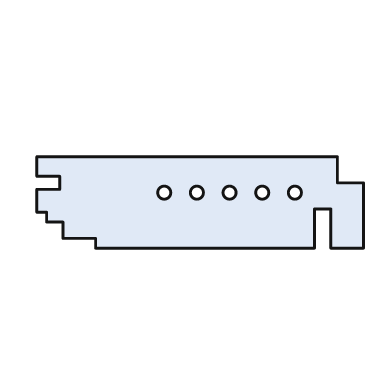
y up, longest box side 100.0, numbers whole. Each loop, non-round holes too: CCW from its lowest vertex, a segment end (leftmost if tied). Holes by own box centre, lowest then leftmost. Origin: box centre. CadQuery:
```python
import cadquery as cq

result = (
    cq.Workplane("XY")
    .moveTo(-32.0, -14.0)
    .lineTo(35.0, -14.0)
    .lineTo(35.0, -2.0)
    .lineTo(40.0, -2.0)
    .lineTo(40.0, -14.0)
    .lineTo(50.0, -14.0)
    .lineTo(50.0, 6.0)
    .lineTo(42.0, 6.0)
    .lineTo(42.0, 14.0)
    .lineTo(-50.0, 14.0)
    .lineTo(-50.0, 8.0)
    .lineTo(-43.0, 8.0)
    .lineTo(-43.0, 4.0)
    .lineTo(-50.0, 4.0)
    .lineTo(-50.0, -3.0)
    .lineTo(-47.0, -3.0)
    .lineTo(-47.0, -6.0)
    .lineTo(-42.0, -6.0)
    .lineTo(-42.0, -11.0)
    .lineTo(-32.0, -11.0)
    .close()
    .moveTo(-11.0, 3.0)
    .circle(2.0)
    .moveTo(-1.0, 3.0)
    .circle(2.0)
    .moveTo(9.0, 3.0)
    .circle(2.0)
    .moveTo(19.0, 3.0)
    .circle(2.0)
    .moveTo(29.0, 3.0)
    .circle(2.0)
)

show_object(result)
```